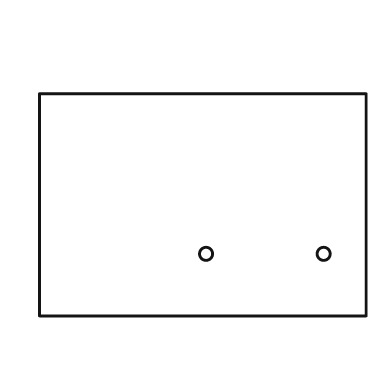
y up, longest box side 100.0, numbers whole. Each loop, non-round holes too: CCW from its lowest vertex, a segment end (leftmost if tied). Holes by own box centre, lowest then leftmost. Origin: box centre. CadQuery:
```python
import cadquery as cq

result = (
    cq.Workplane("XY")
    .moveTo(-50.0, -34.0)
    .lineTo(50.0, -34.0)
    .lineTo(50.0, 34.0)
    .lineTo(-50.0, 34.0)
    .close()
    .moveTo(1.0, -15.0)
    .circle(2.0)
    .moveTo(37.0, -15.0)
    .circle(2.0)
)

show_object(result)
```